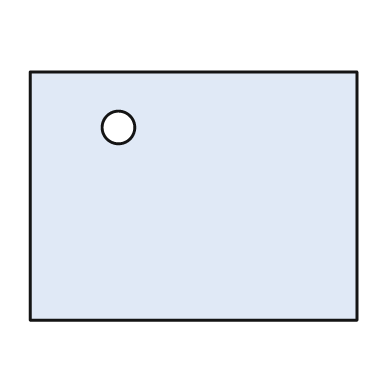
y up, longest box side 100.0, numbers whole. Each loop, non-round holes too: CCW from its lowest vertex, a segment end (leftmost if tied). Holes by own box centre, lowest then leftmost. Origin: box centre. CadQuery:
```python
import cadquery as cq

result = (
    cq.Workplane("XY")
    .moveTo(-50.0, -38.0)
    .lineTo(50.0, -38.0)
    .lineTo(50.0, 38.0)
    .lineTo(-50.0, 38.0)
    .close()
    .moveTo(-23.0, 21.0)
    .circle(5.0)
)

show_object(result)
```